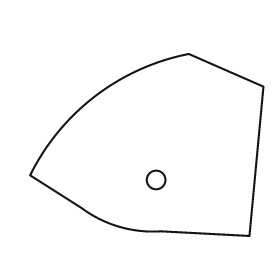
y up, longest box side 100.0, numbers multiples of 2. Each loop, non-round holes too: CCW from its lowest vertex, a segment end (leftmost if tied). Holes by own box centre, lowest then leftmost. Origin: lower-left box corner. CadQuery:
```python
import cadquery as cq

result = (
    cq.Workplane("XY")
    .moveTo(94.0, 0.0)
    .lineTo(100.0, 64.0)
    .lineTo(68.0, 78.0)
    .threePointArc((28.0, 60.0), (0.0, 26.0))
    .lineTo(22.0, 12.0)
    .threePointArc((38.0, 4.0), (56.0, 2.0))
    .close()
    .moveTo(54.0, 24.0)
    .circle(4.0)
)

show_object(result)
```